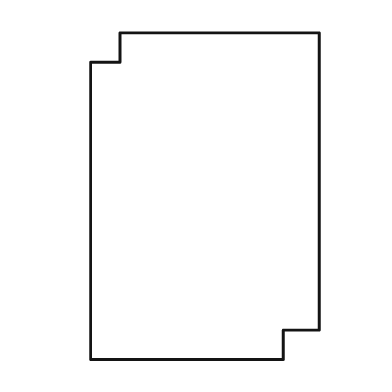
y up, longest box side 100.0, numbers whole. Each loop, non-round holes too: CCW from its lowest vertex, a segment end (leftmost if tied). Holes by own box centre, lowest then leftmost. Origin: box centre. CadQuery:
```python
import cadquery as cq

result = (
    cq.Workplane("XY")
    .moveTo(-35.0, -50.0)
    .lineTo(24.0, -50.0)
    .lineTo(24.0, -41.0)
    .lineTo(35.0, -41.0)
    .lineTo(35.0, 50.0)
    .lineTo(-26.0, 50.0)
    .lineTo(-26.0, 41.0)
    .lineTo(-35.0, 41.0)
    .close()
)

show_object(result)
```